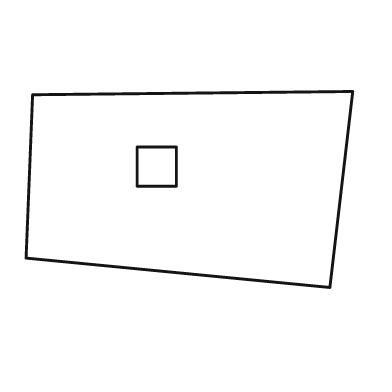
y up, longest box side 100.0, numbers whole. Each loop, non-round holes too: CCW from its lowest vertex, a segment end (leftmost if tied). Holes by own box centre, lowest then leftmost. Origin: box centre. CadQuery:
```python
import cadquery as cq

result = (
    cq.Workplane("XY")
    .moveTo(43.0, -30.0)
    .lineTo(50.0, 30.0)
    .lineTo(-48.0, 29.0)
    .lineTo(-50.0, -21.0)
    .close()
    .moveTo(-16.0, 1.0)
    .lineTo(-4.0, 1.0)
    .lineTo(-4.0, 13.0)
    .lineTo(-16.0, 13.0)
    .close()
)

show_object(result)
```